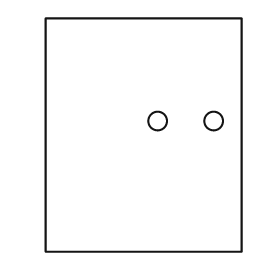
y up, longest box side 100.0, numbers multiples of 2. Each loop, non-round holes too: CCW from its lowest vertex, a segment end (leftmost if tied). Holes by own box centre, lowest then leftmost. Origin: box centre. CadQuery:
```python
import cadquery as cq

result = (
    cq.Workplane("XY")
    .moveTo(-42.0, -50.0)
    .lineTo(42.0, -50.0)
    .lineTo(42.0, 50.0)
    .lineTo(-42.0, 50.0)
    .close()
    .moveTo(6.0, 6.0)
    .circle(4.0)
    .moveTo(30.0, 6.0)
    .circle(4.0)
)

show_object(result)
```